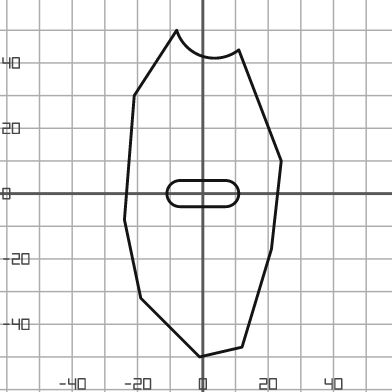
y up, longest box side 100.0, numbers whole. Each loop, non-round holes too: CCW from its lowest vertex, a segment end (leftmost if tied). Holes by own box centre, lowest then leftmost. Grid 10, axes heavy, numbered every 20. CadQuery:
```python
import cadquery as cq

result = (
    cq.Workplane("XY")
    .moveTo(-1.0, -50.0)
    .lineTo(12.0, -47.0)
    .lineTo(21.0, -17.0)
    .lineTo(24.0, 10.0)
    .lineTo(11.0, 44.0)
    .threePointArc((0.0, 42.0), (-8.0, 50.0))
    .lineTo(-21.0, 30.0)
    .lineTo(-24.0, -8.0)
    .lineTo(-19.0, -32.0)
    .close()
    .moveTo(-7.0, -4.0)
    .lineTo(7.0, -4.0)
    .threePointArc((11.0, 0.0), (7.0, 4.0))
    .lineTo(-7.0, 4.0)
    .threePointArc((-11.0, 0.0), (-7.0, -4.0))
    .close()
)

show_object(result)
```